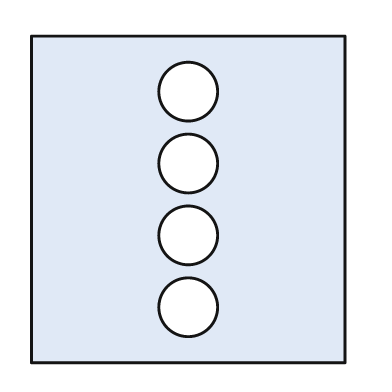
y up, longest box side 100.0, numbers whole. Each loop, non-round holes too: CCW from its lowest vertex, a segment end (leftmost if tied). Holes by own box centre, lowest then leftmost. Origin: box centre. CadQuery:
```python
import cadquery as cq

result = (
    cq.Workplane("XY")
    .moveTo(-48.0, -50.0)
    .lineTo(48.0, -50.0)
    .lineTo(48.0, 50.0)
    .lineTo(-48.0, 50.0)
    .close()
    .moveTo(0.0, -33.0)
    .circle(9.0)
    .moveTo(0.0, -11.0)
    .circle(9.0)
    .moveTo(0.0, 11.0)
    .circle(9.0)
    .moveTo(0.0, 33.0)
    .circle(9.0)
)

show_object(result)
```